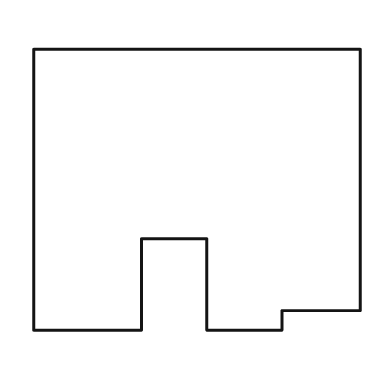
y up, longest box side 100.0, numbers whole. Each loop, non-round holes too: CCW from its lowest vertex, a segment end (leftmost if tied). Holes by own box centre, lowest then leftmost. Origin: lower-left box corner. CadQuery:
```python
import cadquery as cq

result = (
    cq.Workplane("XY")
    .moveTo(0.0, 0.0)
    .lineTo(33.0, 0.0)
    .lineTo(33.0, 28.0)
    .lineTo(53.0, 28.0)
    .lineTo(53.0, 0.0)
    .lineTo(76.0, 0.0)
    .lineTo(76.0, 6.0)
    .lineTo(100.0, 6.0)
    .lineTo(100.0, 86.0)
    .lineTo(0.0, 86.0)
    .close()
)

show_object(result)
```